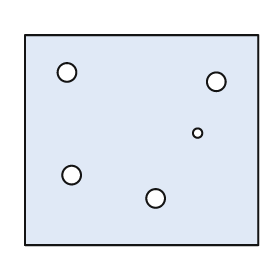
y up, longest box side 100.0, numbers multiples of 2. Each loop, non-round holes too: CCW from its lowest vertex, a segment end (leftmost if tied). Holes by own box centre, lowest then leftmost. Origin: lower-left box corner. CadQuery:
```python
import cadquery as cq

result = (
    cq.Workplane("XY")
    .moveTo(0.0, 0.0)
    .lineTo(100.0, 0.0)
    .lineTo(100.0, 90.0)
    .lineTo(0.0, 90.0)
    .close()
    .moveTo(56.0, 20.0)
    .circle(4.0)
    .moveTo(20.0, 30.0)
    .circle(4.0)
    .moveTo(74.0, 48.0)
    .circle(2.0)
    .moveTo(82.0, 70.0)
    .circle(4.0)
    .moveTo(18.0, 74.0)
    .circle(4.0)
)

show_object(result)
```